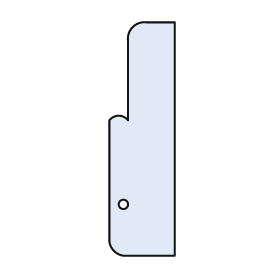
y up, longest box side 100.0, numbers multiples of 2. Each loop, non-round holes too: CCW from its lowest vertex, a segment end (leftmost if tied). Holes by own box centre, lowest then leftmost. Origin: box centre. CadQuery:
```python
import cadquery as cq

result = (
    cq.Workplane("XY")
    .moveTo(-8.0, -50.0)
    .lineTo(14.0, -50.0)
    .lineTo(14.0, 50.0)
    .lineTo(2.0, 50.0)
    .threePointArc((-4.0, 48.0), (-6.0, 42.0))
    .lineTo(-6.0, 8.0)
    .threePointArc((-10.0, 10.0), (-14.0, 8.0))
    .lineTo(-14.0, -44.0)
    .threePointArc((-12.0, -48.0), (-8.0, -50.0))
    .close()
    .moveTo(-8.0, -28.0)
    .circle(2.0)
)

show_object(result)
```